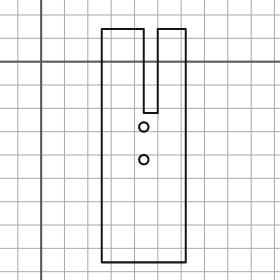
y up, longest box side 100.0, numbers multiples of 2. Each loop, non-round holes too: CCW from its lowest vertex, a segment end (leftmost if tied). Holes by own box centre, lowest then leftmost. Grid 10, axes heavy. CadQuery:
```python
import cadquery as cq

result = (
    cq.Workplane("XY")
    .moveTo(26.0, -86.0)
    .lineTo(62.0, -86.0)
    .lineTo(62.0, 14.0)
    .lineTo(50.0, 14.0)
    .lineTo(50.0, -22.0)
    .lineTo(44.0, -22.0)
    .lineTo(44.0, 14.0)
    .lineTo(26.0, 14.0)
    .close()
    .moveTo(44.0, -42.0)
    .circle(2.0)
    .moveTo(44.0, -28.0)
    .circle(2.0)
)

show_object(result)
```